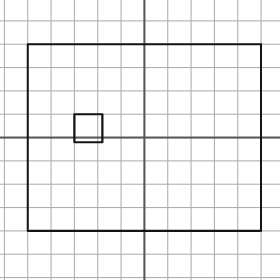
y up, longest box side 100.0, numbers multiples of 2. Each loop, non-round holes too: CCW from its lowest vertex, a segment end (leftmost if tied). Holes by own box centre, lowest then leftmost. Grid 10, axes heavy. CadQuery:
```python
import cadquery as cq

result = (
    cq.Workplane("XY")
    .moveTo(-50.0, -40.0)
    .lineTo(50.0, -40.0)
    .lineTo(50.0, 40.0)
    .lineTo(-50.0, 40.0)
    .close()
    .moveTo(-30.0, -2.0)
    .lineTo(-18.0, -2.0)
    .lineTo(-18.0, 10.0)
    .lineTo(-30.0, 10.0)
    .close()
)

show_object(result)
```